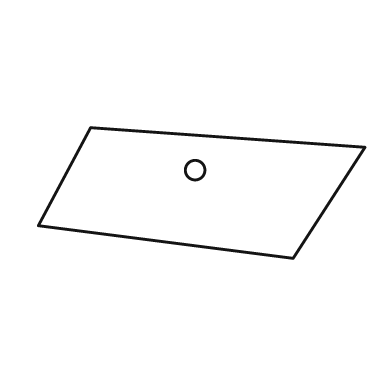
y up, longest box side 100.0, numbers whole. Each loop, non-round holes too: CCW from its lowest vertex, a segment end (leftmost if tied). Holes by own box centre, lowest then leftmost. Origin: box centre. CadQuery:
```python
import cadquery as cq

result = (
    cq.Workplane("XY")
    .moveTo(28.0, -20.0)
    .lineTo(50.0, 14.0)
    .lineTo(-34.0, 20.0)
    .lineTo(-50.0, -10.0)
    .close()
    .moveTo(-2.0, 7.0)
    .circle(3.0)
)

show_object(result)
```